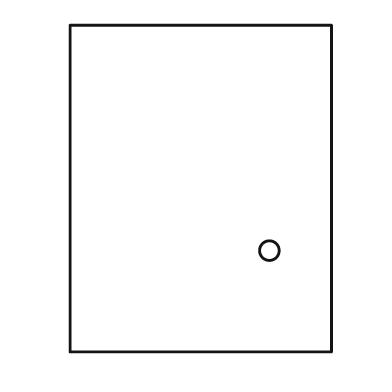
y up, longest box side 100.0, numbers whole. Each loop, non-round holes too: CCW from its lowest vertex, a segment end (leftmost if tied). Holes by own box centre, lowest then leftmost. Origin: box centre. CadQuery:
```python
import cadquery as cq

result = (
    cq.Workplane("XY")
    .moveTo(-40.0, -50.0)
    .lineTo(40.0, -50.0)
    .lineTo(40.0, 50.0)
    .lineTo(-40.0, 50.0)
    .close()
    .moveTo(21.0, -19.0)
    .circle(3.0)
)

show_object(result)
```